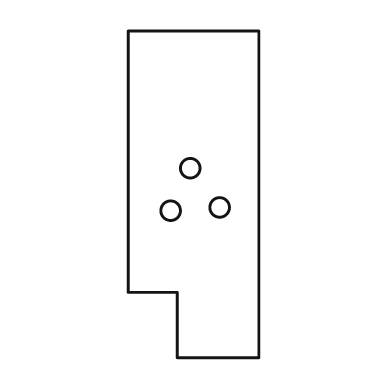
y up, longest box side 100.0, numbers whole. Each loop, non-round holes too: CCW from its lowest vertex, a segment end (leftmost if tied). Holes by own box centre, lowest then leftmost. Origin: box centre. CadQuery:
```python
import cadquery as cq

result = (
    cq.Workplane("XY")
    .moveTo(-5.0, -50.0)
    .lineTo(20.0, -50.0)
    .lineTo(20.0, 50.0)
    .lineTo(-20.0, 50.0)
    .lineTo(-20.0, -30.0)
    .lineTo(-5.0, -30.0)
    .close()
    .moveTo(-7.0, -5.0)
    .circle(3.0)
    .moveTo(8.0, -4.0)
    .circle(3.0)
    .moveTo(-1.0, 8.0)
    .circle(3.0)
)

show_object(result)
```